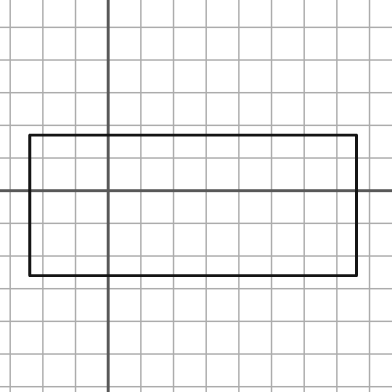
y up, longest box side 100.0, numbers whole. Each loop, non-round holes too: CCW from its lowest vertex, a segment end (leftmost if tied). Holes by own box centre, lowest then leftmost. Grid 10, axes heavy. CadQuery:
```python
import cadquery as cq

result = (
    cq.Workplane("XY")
    .moveTo(-24.0, -26.0)
    .lineTo(76.0, -26.0)
    .lineTo(76.0, 17.0)
    .lineTo(-24.0, 17.0)
    .close()
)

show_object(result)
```